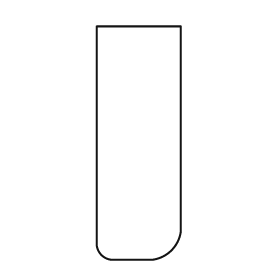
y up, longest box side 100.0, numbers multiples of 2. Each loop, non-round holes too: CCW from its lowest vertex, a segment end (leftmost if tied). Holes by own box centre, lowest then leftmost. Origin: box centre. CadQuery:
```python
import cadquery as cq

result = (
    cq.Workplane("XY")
    .moveTo(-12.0, -50.0)
    .lineTo(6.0, -50.0)
    .threePointArc((14.0, -46.0), (18.0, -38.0))
    .lineTo(18.0, 50.0)
    .lineTo(-18.0, 50.0)
    .lineTo(-18.0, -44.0)
    .threePointArc((-16.0, -48.0), (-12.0, -50.0))
    .close()
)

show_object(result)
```